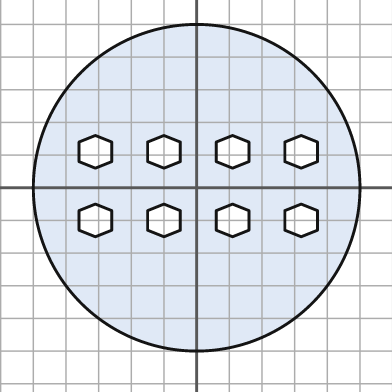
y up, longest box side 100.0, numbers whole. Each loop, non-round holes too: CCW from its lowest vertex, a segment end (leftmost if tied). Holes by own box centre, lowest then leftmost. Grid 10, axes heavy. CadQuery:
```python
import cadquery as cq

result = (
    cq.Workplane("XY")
    .moveTo(0.0, 0.0)
    .circle(50.0)
    .moveTo(-31.0, -15.0)
    .lineTo(-26.0, -13.0)
    .lineTo(-26.0, -7.0)
    .lineTo(-31.0, -5.0)
    .lineTo(-36.0, -7.0)
    .lineTo(-36.0, -13.0)
    .close()
    .moveTo(-10.0, -15.0)
    .lineTo(-5.0, -13.0)
    .lineTo(-5.0, -7.0)
    .lineTo(-10.0, -5.0)
    .lineTo(-15.0, -7.0)
    .lineTo(-15.0, -13.0)
    .close()
    .moveTo(11.0, -15.0)
    .lineTo(16.0, -13.0)
    .lineTo(16.0, -7.0)
    .lineTo(11.0, -5.0)
    .lineTo(6.0, -7.0)
    .lineTo(6.0, -13.0)
    .close()
    .moveTo(32.0, -15.0)
    .lineTo(37.0, -13.0)
    .lineTo(37.0, -7.0)
    .lineTo(32.0, -5.0)
    .lineTo(27.0, -7.0)
    .lineTo(27.0, -13.0)
    .close()
    .moveTo(-31.0, 6.0)
    .lineTo(-26.0, 8.0)
    .lineTo(-26.0, 14.0)
    .lineTo(-31.0, 16.0)
    .lineTo(-36.0, 14.0)
    .lineTo(-36.0, 8.0)
    .close()
    .moveTo(-10.0, 6.0)
    .lineTo(-5.0, 8.0)
    .lineTo(-5.0, 14.0)
    .lineTo(-10.0, 16.0)
    .lineTo(-15.0, 14.0)
    .lineTo(-15.0, 8.0)
    .close()
    .moveTo(11.0, 6.0)
    .lineTo(16.0, 8.0)
    .lineTo(16.0, 14.0)
    .lineTo(11.0, 16.0)
    .lineTo(6.0, 14.0)
    .lineTo(6.0, 8.0)
    .close()
    .moveTo(32.0, 6.0)
    .lineTo(37.0, 8.0)
    .lineTo(37.0, 14.0)
    .lineTo(32.0, 16.0)
    .lineTo(27.0, 14.0)
    .lineTo(27.0, 8.0)
    .close()
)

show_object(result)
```